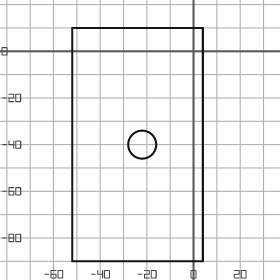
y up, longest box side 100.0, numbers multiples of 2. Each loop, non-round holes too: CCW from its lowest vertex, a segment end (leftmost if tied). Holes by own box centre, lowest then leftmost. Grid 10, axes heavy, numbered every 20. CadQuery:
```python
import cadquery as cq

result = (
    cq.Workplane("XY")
    .moveTo(-52.0, -90.0)
    .lineTo(4.0, -90.0)
    .lineTo(4.0, 10.0)
    .lineTo(-52.0, 10.0)
    .close()
    .moveTo(-22.0, -40.0)
    .circle(6.0)
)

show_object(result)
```